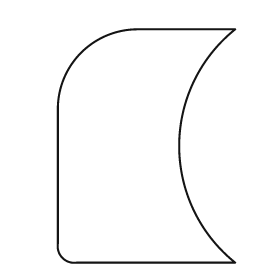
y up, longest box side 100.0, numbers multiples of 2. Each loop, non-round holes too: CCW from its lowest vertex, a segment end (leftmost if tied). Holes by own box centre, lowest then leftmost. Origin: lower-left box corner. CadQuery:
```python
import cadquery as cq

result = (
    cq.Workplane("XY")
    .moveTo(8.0, 0.0)
    .lineTo(76.0, 0.0)
    .threePointArc((52.0, 50.0), (76.0, 100.0))
    .lineTo(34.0, 100.0)
    .threePointArc((10.0, 90.0), (0.0, 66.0))
    .lineTo(0.0, 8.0)
    .threePointArc((2.0, 2.0), (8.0, 0.0))
    .close()
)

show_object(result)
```